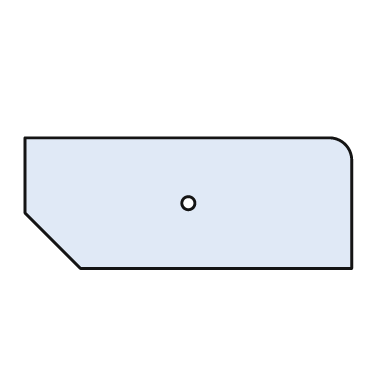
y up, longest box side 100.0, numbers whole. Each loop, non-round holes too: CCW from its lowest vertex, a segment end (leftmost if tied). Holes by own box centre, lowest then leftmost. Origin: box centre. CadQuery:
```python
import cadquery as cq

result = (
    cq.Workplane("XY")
    .moveTo(-33.0, -20.0)
    .lineTo(50.0, -20.0)
    .lineTo(50.0, 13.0)
    .threePointArc((48.0, 18.0), (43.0, 20.0))
    .lineTo(-50.0, 20.0)
    .lineTo(-50.0, -3.0)
    .close()
    .moveTo(0.0, 0.0)
    .circle(2.0)
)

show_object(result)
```